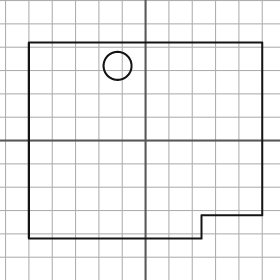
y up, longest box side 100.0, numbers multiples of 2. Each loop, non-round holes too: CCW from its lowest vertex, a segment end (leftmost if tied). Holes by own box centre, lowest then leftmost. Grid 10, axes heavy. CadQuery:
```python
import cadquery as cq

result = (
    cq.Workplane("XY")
    .moveTo(-50.0, -42.0)
    .lineTo(24.0, -42.0)
    .lineTo(24.0, -32.0)
    .lineTo(50.0, -32.0)
    .lineTo(50.0, 42.0)
    .lineTo(-50.0, 42.0)
    .close()
    .moveTo(-12.0, 32.0)
    .circle(6.0)
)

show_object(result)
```